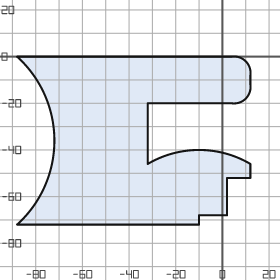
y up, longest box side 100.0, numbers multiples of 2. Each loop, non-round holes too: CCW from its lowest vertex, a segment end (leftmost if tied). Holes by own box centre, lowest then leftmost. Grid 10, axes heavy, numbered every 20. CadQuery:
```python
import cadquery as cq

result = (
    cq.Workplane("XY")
    .moveTo(-88.0, -72.0)
    .lineTo(-10.0, -72.0)
    .lineTo(-10.0, -68.0)
    .lineTo(2.0, -68.0)
    .lineTo(2.0, -52.0)
    .lineTo(12.0, -52.0)
    .lineTo(12.0, -46.0)
    .threePointArc((-10.0, -40.0), (-32.0, -46.0))
    .lineTo(-32.0, -20.0)
    .lineTo(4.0, -20.0)
    .threePointArc((10.0, -18.0), (12.0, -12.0))
    .lineTo(12.0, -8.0)
    .threePointArc((10.0, -2.0), (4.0, 0.0))
    .lineTo(-88.0, 0.0)
    .threePointArc((-72.0, -36.0), (-88.0, -72.0))
    .close()
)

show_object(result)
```